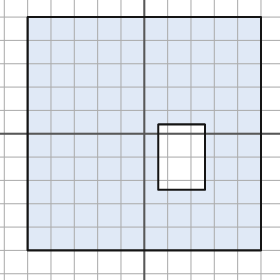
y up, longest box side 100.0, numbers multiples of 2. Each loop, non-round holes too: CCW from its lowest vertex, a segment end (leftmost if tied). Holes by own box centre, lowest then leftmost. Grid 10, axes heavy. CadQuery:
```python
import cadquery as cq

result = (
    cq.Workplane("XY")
    .moveTo(-50.0, -50.0)
    .lineTo(50.0, -50.0)
    .lineTo(50.0, 50.0)
    .lineTo(-50.0, 50.0)
    .close()
    .moveTo(6.0, -24.0)
    .lineTo(26.0, -24.0)
    .lineTo(26.0, 4.0)
    .lineTo(6.0, 4.0)
    .close()
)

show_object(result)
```